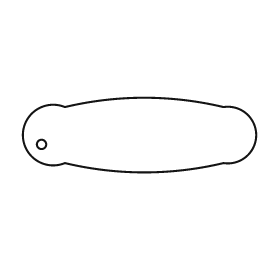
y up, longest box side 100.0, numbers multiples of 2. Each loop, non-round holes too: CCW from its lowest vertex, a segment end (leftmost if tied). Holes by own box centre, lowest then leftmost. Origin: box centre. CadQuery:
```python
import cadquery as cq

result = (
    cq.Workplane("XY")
    .moveTo(-32.0, -12.0)
    .threePointArc((2.0, -16.0), (36.0, -12.0))
    .threePointArc((50.0, 0.0), (36.0, 12.0))
    .threePointArc((2.0, 16.0), (-32.0, 12.0))
    .threePointArc((-50.0, 0.0), (-32.0, -12.0))
    .close()
    .moveTo(-42.0, -4.0)
    .circle(2.0)
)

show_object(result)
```